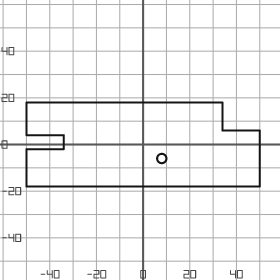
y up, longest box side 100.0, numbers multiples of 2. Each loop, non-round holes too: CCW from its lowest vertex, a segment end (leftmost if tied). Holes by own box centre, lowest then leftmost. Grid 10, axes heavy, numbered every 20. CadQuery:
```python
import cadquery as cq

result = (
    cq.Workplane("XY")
    .moveTo(-50.0, -18.0)
    .lineTo(50.0, -18.0)
    .lineTo(50.0, 6.0)
    .lineTo(34.0, 6.0)
    .lineTo(34.0, 18.0)
    .lineTo(-50.0, 18.0)
    .lineTo(-50.0, 4.0)
    .lineTo(-34.0, 4.0)
    .lineTo(-34.0, -2.0)
    .lineTo(-50.0, -2.0)
    .close()
    .moveTo(8.0, -6.0)
    .circle(2.0)
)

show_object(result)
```